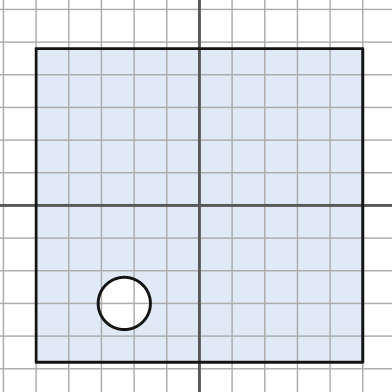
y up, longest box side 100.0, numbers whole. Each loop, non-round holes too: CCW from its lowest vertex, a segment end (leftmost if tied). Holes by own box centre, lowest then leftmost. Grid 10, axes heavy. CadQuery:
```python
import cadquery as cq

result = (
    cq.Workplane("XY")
    .moveTo(-50.0, -48.0)
    .lineTo(50.0, -48.0)
    .lineTo(50.0, 48.0)
    .lineTo(-50.0, 48.0)
    .close()
    .moveTo(-23.0, -30.0)
    .circle(8.0)
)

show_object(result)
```